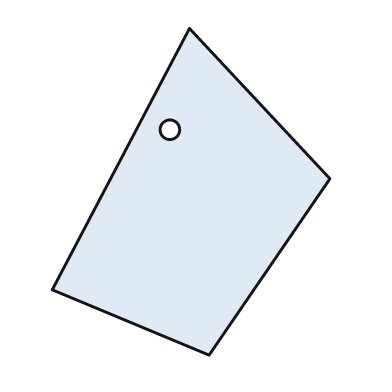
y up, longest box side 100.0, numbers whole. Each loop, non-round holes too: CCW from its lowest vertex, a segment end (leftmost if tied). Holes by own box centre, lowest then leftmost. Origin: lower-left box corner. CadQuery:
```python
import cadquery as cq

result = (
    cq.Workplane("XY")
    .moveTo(48.0, 0.0)
    .lineTo(85.0, 54.0)
    .lineTo(42.0, 100.0)
    .lineTo(0.0, 20.0)
    .close()
    .moveTo(36.0, 69.0)
    .circle(3.0)
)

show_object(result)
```